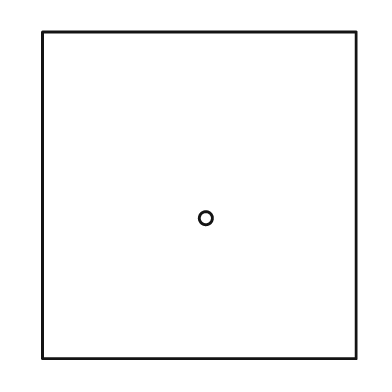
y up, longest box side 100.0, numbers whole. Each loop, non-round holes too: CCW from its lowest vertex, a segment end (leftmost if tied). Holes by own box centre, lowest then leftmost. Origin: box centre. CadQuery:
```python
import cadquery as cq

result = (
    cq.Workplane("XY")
    .moveTo(-48.0, -50.0)
    .lineTo(48.0, -50.0)
    .lineTo(48.0, 50.0)
    .lineTo(-48.0, 50.0)
    .close()
    .moveTo(2.0, -7.0)
    .circle(2.0)
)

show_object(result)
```